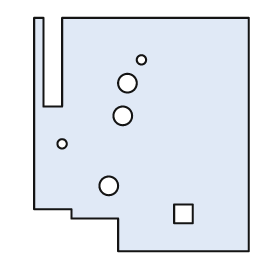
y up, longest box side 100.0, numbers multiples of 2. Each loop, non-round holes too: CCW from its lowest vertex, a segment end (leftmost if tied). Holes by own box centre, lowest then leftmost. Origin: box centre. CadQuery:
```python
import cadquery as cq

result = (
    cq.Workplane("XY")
    .moveTo(-10.0, -50.0)
    .lineTo(46.0, -50.0)
    .lineTo(46.0, 50.0)
    .lineTo(-34.0, 50.0)
    .lineTo(-34.0, 12.0)
    .lineTo(-42.0, 12.0)
    .lineTo(-42.0, 50.0)
    .lineTo(-46.0, 50.0)
    .lineTo(-46.0, -32.0)
    .lineTo(-30.0, -32.0)
    .lineTo(-30.0, -36.0)
    .lineTo(-10.0, -36.0)
    .close()
    .moveTo(14.0, -38.0)
    .lineTo(22.0, -38.0)
    .lineTo(22.0, -30.0)
    .lineTo(14.0, -30.0)
    .close()
    .moveTo(-14.0, -22.0)
    .circle(4.0)
    .moveTo(-34.0, -4.0)
    .circle(2.0)
    .moveTo(-8.0, 8.0)
    .circle(4.0)
    .moveTo(-6.0, 22.0)
    .circle(4.0)
    .moveTo(0.0, 32.0)
    .circle(2.0)
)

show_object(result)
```